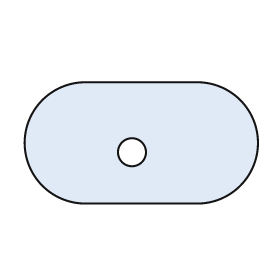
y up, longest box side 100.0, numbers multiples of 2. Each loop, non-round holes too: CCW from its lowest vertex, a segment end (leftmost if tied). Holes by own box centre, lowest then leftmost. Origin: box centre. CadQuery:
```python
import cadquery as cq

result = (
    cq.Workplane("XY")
    .moveTo(-24.0, -26.0)
    .lineTo(24.0, -26.0)
    .threePointArc((50.0, 0.0), (24.0, 26.0))
    .lineTo(-24.0, 26.0)
    .threePointArc((-50.0, 0.0), (-24.0, -26.0))
    .close()
    .moveTo(-4.0, -4.0)
    .circle(6.0)
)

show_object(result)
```